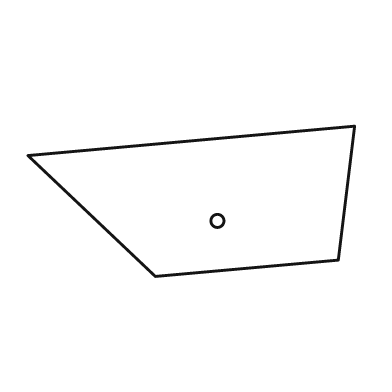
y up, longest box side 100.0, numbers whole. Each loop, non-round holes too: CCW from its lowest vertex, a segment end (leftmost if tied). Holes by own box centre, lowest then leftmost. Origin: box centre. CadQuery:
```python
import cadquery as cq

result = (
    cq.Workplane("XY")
    .moveTo(-11.0, -23.0)
    .lineTo(45.0, -18.0)
    .lineTo(50.0, 23.0)
    .lineTo(-50.0, 14.0)
    .close()
    .moveTo(8.0, -6.0)
    .circle(2.0)
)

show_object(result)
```